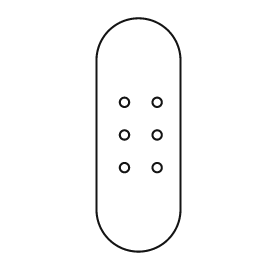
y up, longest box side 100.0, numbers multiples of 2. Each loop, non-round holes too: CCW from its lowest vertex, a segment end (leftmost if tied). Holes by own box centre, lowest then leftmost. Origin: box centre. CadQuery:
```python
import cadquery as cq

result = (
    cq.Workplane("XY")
    .moveTo(-18.0, -32.0)
    .threePointArc((0.0, -50.0), (18.0, -32.0))
    .lineTo(18.0, 32.0)
    .threePointArc((0.0, 50.0), (-18.0, 32.0))
    .close()
    .moveTo(-6.0, -14.0)
    .circle(2.0)
    .moveTo(8.0, -14.0)
    .circle(2.0)
    .moveTo(-6.0, 0.0)
    .circle(2.0)
    .moveTo(8.0, 0.0)
    .circle(2.0)
    .moveTo(-6.0, 14.0)
    .circle(2.0)
    .moveTo(8.0, 14.0)
    .circle(2.0)
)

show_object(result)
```